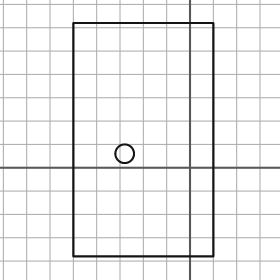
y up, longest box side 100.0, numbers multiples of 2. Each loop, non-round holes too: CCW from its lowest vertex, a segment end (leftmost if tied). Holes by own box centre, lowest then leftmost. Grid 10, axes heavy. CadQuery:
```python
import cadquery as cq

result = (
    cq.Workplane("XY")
    .moveTo(-50.0, -38.0)
    .lineTo(10.0, -38.0)
    .lineTo(10.0, 62.0)
    .lineTo(-50.0, 62.0)
    .close()
    .moveTo(-28.0, 6.0)
    .circle(4.0)
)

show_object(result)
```